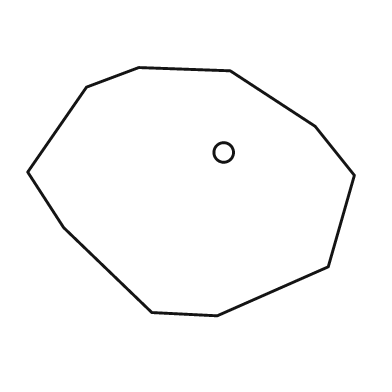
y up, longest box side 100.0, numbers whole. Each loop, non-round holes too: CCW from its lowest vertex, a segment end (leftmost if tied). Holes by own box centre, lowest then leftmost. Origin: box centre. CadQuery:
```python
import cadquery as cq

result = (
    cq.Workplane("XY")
    .moveTo(8.0, -38.0)
    .lineTo(42.0, -23.0)
    .lineTo(50.0, 5.0)
    .lineTo(38.0, 20.0)
    .lineTo(12.0, 37.0)
    .lineTo(-16.0, 38.0)
    .lineTo(-32.0, 32.0)
    .lineTo(-50.0, 6.0)
    .lineTo(-39.0, -11.0)
    .lineTo(-12.0, -37.0)
    .close()
    .moveTo(10.0, 12.0)
    .circle(3.0)
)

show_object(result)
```